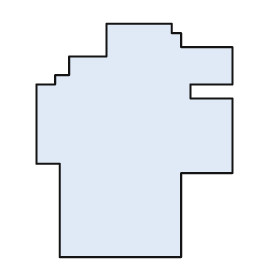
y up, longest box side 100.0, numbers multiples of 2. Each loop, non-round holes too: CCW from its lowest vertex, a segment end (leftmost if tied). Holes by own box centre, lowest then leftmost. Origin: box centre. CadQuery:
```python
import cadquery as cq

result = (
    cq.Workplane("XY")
    .moveTo(-32.0, -50.0)
    .lineTo(20.0, -50.0)
    .lineTo(20.0, -14.0)
    .lineTo(42.0, -14.0)
    .lineTo(42.0, 18.0)
    .lineTo(24.0, 18.0)
    .lineTo(24.0, 24.0)
    .lineTo(42.0, 24.0)
    .lineTo(42.0, 40.0)
    .lineTo(20.0, 40.0)
    .lineTo(20.0, 46.0)
    .lineTo(16.0, 46.0)
    .lineTo(16.0, 50.0)
    .lineTo(-12.0, 50.0)
    .lineTo(-12.0, 36.0)
    .lineTo(-28.0, 36.0)
    .lineTo(-28.0, 28.0)
    .lineTo(-34.0, 28.0)
    .lineTo(-34.0, 24.0)
    .lineTo(-42.0, 24.0)
    .lineTo(-42.0, -10.0)
    .lineTo(-32.0, -10.0)
    .close()
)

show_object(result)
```